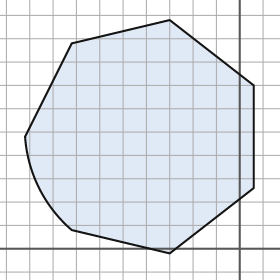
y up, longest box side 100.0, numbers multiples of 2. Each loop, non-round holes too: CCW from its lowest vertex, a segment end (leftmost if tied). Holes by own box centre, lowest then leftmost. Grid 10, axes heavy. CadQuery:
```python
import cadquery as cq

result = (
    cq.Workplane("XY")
    .moveTo(-30.0, -2.0)
    .lineTo(6.0, 26.0)
    .lineTo(6.0, 70.0)
    .lineTo(-30.0, 98.0)
    .lineTo(-72.0, 88.0)
    .lineTo(-92.0, 48.0)
    .threePointArc((-86.0, 26.0), (-72.0, 8.0))
    .close()
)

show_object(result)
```